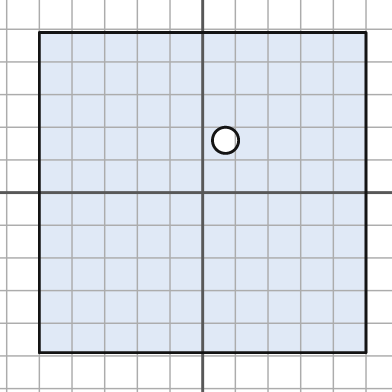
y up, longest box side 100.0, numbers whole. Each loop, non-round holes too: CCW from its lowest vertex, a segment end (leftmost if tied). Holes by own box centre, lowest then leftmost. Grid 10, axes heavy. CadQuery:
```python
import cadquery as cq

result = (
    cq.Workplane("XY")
    .moveTo(-50.0, -49.0)
    .lineTo(50.0, -49.0)
    .lineTo(50.0, 49.0)
    .lineTo(-50.0, 49.0)
    .close()
    .moveTo(7.0, 16.0)
    .circle(4.0)
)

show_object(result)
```